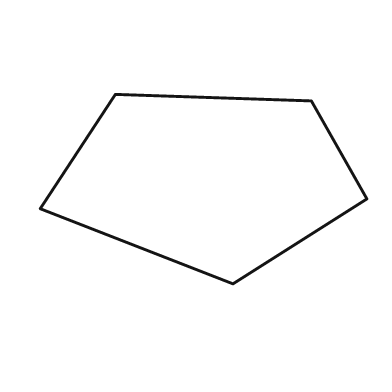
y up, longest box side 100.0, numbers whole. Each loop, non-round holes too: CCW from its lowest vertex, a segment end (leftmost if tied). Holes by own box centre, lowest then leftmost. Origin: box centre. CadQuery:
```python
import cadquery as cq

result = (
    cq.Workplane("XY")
    .moveTo(9.0, -29.0)
    .lineTo(50.0, -3.0)
    .lineTo(33.0, 27.0)
    .lineTo(-27.0, 29.0)
    .lineTo(-50.0, -6.0)
    .close()
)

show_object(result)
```